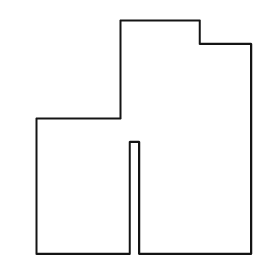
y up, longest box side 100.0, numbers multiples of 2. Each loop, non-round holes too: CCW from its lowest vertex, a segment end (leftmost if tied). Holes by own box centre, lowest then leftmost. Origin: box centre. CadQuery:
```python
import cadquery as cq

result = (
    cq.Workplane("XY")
    .moveTo(-46.0, -50.0)
    .lineTo(-6.0, -50.0)
    .lineTo(-6.0, -2.0)
    .lineTo(-2.0, -2.0)
    .lineTo(-2.0, -50.0)
    .lineTo(46.0, -50.0)
    .lineTo(46.0, 40.0)
    .lineTo(24.0, 40.0)
    .lineTo(24.0, 50.0)
    .lineTo(-10.0, 50.0)
    .lineTo(-10.0, 8.0)
    .lineTo(-46.0, 8.0)
    .close()
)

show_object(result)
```